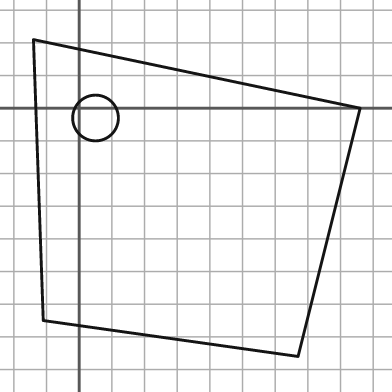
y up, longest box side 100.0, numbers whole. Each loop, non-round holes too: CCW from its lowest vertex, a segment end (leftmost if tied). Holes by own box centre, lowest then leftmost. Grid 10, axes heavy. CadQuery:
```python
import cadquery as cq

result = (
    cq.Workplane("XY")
    .moveTo(67.0, -76.0)
    .lineTo(86.0, 0.0)
    .lineTo(-14.0, 21.0)
    .lineTo(-11.0, -65.0)
    .close()
    .moveTo(5.0, -3.0)
    .circle(7.0)
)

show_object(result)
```